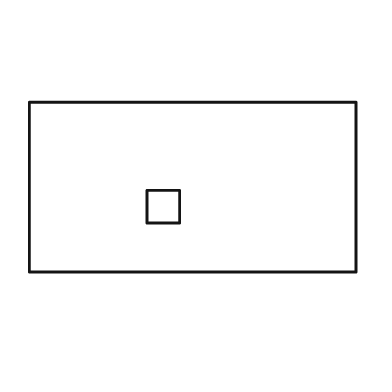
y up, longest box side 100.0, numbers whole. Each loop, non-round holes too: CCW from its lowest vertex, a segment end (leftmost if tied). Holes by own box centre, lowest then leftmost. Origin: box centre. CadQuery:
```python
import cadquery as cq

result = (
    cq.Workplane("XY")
    .moveTo(-50.0, -26.0)
    .lineTo(50.0, -26.0)
    .lineTo(50.0, 26.0)
    .lineTo(-50.0, 26.0)
    .close()
    .moveTo(-14.0, -11.0)
    .lineTo(-4.0, -11.0)
    .lineTo(-4.0, -1.0)
    .lineTo(-14.0, -1.0)
    .close()
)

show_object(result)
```